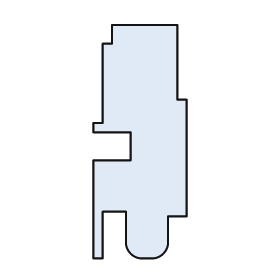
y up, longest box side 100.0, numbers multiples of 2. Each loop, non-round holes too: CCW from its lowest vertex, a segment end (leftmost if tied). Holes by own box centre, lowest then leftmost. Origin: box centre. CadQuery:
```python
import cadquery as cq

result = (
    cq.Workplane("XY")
    .moveTo(-20.0, -50.0)
    .lineTo(-16.0, -50.0)
    .lineTo(-16.0, -30.0)
    .lineTo(-6.0, -30.0)
    .lineTo(-6.0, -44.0)
    .threePointArc((-4.0, -48.0), (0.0, -50.0))
    .lineTo(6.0, -50.0)
    .threePointArc((10.0, -48.0), (12.0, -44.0))
    .lineTo(12.0, -32.0)
    .lineTo(20.0, -32.0)
    .lineTo(20.0, 18.0)
    .lineTo(16.0, 18.0)
    .lineTo(16.0, 50.0)
    .lineTo(-12.0, 50.0)
    .lineTo(-12.0, 42.0)
    .lineTo(-16.0, 42.0)
    .lineTo(-16.0, 8.0)
    .lineTo(-20.0, 8.0)
    .lineTo(-20.0, 4.0)
    .lineTo(-4.0, 4.0)
    .lineTo(-4.0, -8.0)
    .lineTo(-20.0, -8.0)
    .close()
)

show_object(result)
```